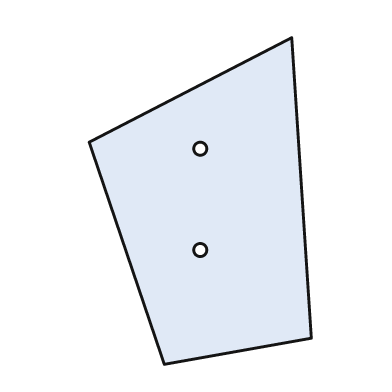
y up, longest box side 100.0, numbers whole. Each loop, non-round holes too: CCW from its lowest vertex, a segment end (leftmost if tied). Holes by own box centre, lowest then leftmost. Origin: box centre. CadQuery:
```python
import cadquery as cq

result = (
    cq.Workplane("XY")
    .moveTo(-11.0, -50.0)
    .lineTo(34.0, -42.0)
    .lineTo(28.0, 50.0)
    .lineTo(-34.0, 18.0)
    .close()
    .moveTo(0.0, -15.0)
    .circle(2.0)
    .moveTo(0.0, 16.0)
    .circle(2.0)
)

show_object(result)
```